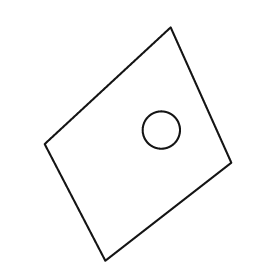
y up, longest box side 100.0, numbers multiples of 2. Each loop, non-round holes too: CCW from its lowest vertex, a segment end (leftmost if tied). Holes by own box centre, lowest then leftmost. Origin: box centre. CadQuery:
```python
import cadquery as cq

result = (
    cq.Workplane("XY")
    .moveTo(-14.0, -50.0)
    .lineTo(40.0, -8.0)
    .lineTo(14.0, 50.0)
    .lineTo(-40.0, 0.0)
    .close()
    .moveTo(10.0, 6.0)
    .circle(8.0)
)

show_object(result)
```